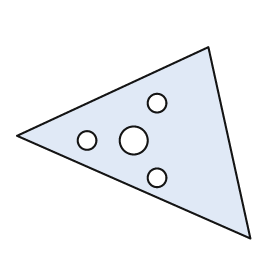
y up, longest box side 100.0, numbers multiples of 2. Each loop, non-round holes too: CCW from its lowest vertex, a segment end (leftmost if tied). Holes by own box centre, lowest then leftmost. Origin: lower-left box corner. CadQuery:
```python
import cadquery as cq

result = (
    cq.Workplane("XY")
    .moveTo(100.0, 0.0)
    .lineTo(82.0, 82.0)
    .lineTo(0.0, 44.0)
    .close()
    .moveTo(60.0, 26.0)
    .circle(4.0)
    .moveTo(30.0, 42.0)
    .circle(4.0)
    .moveTo(50.0, 42.0)
    .circle(6.0)
    .moveTo(60.0, 58.0)
    .circle(4.0)
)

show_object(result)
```